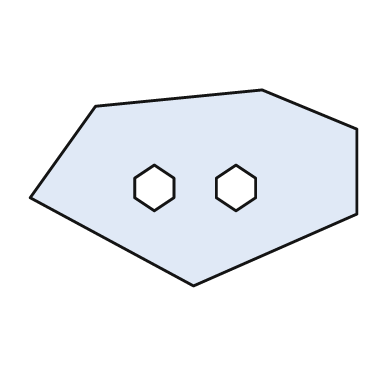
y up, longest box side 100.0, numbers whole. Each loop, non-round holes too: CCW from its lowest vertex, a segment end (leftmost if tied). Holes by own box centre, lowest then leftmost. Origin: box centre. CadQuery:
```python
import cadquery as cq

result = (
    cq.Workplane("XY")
    .moveTo(0.0, -30.0)
    .lineTo(50.0, -8.0)
    .lineTo(50.0, 18.0)
    .lineTo(21.0, 30.0)
    .lineTo(-30.0, 25.0)
    .lineTo(-50.0, -3.0)
    .close()
    .moveTo(-12.0, -7.0)
    .lineTo(-6.0, -3.0)
    .lineTo(-6.0, 3.0)
    .lineTo(-12.0, 7.0)
    .lineTo(-18.0, 3.0)
    .lineTo(-18.0, -3.0)
    .close()
    .moveTo(13.0, -7.0)
    .lineTo(19.0, -3.0)
    .lineTo(19.0, 3.0)
    .lineTo(13.0, 7.0)
    .lineTo(7.0, 3.0)
    .lineTo(7.0, -3.0)
    .close()
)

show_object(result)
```